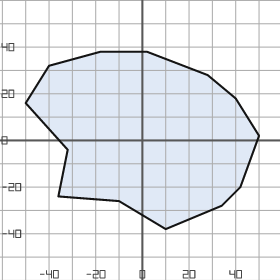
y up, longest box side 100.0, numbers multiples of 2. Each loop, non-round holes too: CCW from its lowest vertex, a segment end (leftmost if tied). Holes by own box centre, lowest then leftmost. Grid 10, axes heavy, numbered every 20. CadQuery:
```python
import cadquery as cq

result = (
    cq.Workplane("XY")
    .moveTo(10.0, -38.0)
    .lineTo(34.0, -28.0)
    .lineTo(42.0, -20.0)
    .lineTo(50.0, 2.0)
    .lineTo(40.0, 18.0)
    .lineTo(28.0, 28.0)
    .lineTo(2.0, 38.0)
    .lineTo(-18.0, 38.0)
    .lineTo(-40.0, 32.0)
    .lineTo(-50.0, 16.0)
    .lineTo(-32.0, -4.0)
    .lineTo(-36.0, -24.0)
    .lineTo(-10.0, -26.0)
    .close()
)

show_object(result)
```